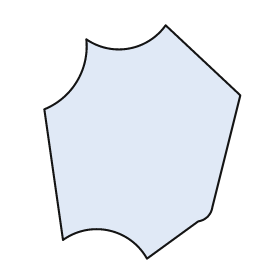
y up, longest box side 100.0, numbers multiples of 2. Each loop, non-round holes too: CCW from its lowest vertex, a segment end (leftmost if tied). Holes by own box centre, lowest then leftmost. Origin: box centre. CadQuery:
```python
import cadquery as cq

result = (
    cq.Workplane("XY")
    .moveTo(2.0, -50.0)
    .lineTo(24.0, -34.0)
    .threePointArc((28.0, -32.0), (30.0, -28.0))
    .lineTo(42.0, 20.0)
    .lineTo(10.0, 50.0)
    .threePointArc((-6.0, 40.0), (-24.0, 44.0))
    .threePointArc((-28.0, 26.0), (-42.0, 14.0))
    .lineTo(-34.0, -42.0)
    .threePointArc((-14.0, -38.0), (2.0, -50.0))
    .close()
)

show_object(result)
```